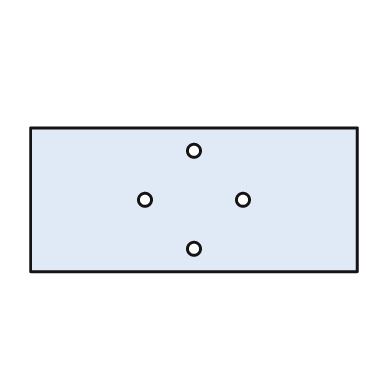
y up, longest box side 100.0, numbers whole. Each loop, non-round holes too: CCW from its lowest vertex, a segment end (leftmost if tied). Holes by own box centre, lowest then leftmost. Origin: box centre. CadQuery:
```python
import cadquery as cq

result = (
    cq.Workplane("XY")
    .moveTo(-50.0, -22.0)
    .lineTo(50.0, -22.0)
    .lineTo(50.0, 22.0)
    .lineTo(-50.0, 22.0)
    .close()
    .moveTo(0.0, -15.0)
    .circle(2.0)
    .moveTo(-15.0, 0.0)
    .circle(2.0)
    .moveTo(15.0, 0.0)
    .circle(2.0)
    .moveTo(0.0, 15.0)
    .circle(2.0)
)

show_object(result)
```